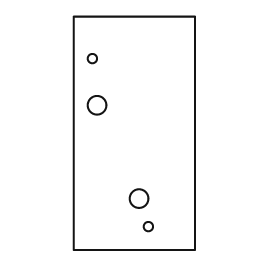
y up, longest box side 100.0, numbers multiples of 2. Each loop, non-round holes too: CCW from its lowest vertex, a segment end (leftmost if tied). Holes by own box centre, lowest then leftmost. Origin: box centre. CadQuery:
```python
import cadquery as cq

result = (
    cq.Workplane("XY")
    .moveTo(-26.0, -50.0)
    .lineTo(26.0, -50.0)
    .lineTo(26.0, 50.0)
    .lineTo(-26.0, 50.0)
    .close()
    .moveTo(6.0, -40.0)
    .circle(2.0)
    .moveTo(2.0, -28.0)
    .circle(4.0)
    .moveTo(-16.0, 12.0)
    .circle(4.0)
    .moveTo(-18.0, 32.0)
    .circle(2.0)
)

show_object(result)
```